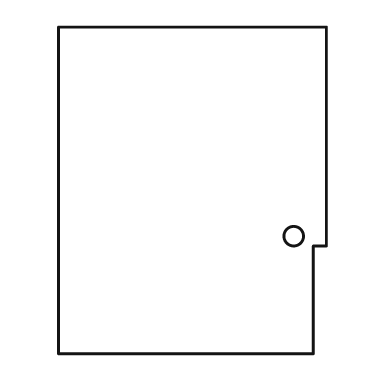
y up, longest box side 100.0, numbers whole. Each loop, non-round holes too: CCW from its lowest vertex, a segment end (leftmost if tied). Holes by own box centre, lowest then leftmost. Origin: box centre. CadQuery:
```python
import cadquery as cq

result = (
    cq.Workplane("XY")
    .moveTo(-41.0, -50.0)
    .lineTo(37.0, -50.0)
    .lineTo(37.0, -17.0)
    .lineTo(41.0, -17.0)
    .lineTo(41.0, 50.0)
    .lineTo(-41.0, 50.0)
    .close()
    .moveTo(31.0, -14.0)
    .circle(3.0)
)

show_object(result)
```